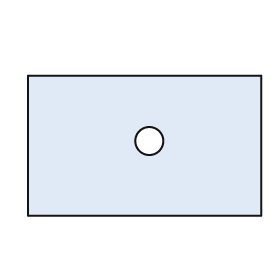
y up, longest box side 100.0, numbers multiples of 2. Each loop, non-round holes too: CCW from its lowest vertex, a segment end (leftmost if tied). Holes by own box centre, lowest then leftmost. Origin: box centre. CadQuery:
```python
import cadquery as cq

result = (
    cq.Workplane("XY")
    .moveTo(-50.0, -30.0)
    .lineTo(50.0, -30.0)
    .lineTo(50.0, 30.0)
    .lineTo(-50.0, 30.0)
    .close()
    .moveTo(2.0, 2.0)
    .circle(6.0)
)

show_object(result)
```